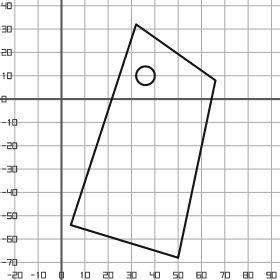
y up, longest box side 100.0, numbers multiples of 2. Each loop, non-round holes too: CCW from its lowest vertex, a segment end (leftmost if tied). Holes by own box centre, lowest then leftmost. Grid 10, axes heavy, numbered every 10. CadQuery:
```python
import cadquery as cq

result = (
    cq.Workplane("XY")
    .moveTo(50.0, -68.0)
    .lineTo(66.0, 8.0)
    .lineTo(32.0, 32.0)
    .lineTo(4.0, -54.0)
    .close()
    .moveTo(36.0, 10.0)
    .circle(4.0)
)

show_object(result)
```